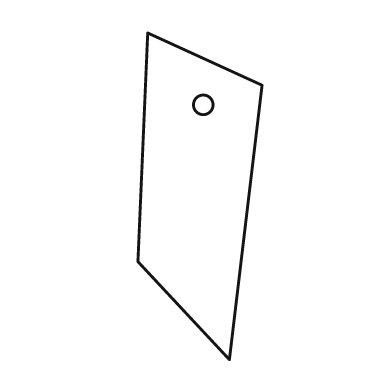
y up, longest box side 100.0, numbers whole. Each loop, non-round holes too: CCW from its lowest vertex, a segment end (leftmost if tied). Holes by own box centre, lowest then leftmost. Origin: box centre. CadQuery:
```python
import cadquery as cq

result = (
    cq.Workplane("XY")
    .moveTo(9.0, -50.0)
    .lineTo(19.0, 34.0)
    .lineTo(-16.0, 50.0)
    .lineTo(-19.0, -20.0)
    .close()
    .moveTo(1.0, 28.0)
    .circle(3.0)
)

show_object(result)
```